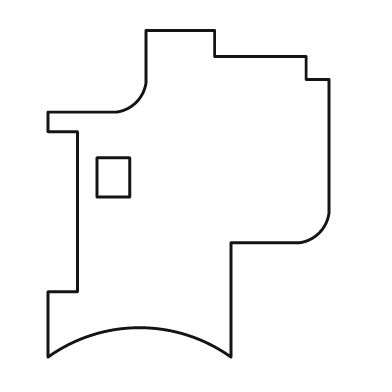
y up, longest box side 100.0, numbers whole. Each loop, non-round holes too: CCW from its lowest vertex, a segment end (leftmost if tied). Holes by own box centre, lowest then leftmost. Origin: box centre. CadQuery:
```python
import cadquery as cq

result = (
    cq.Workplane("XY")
    .moveTo(-43.0, -50.0)
    .threePointArc((-15.0, -41.0), (13.0, -50.0))
    .lineTo(13.0, -15.0)
    .lineTo(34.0, -15.0)
    .threePointArc((40.0, -12.0), (43.0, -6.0))
    .lineTo(43.0, 35.0)
    .lineTo(36.0, 35.0)
    .lineTo(36.0, 42.0)
    .lineTo(8.0, 42.0)
    .lineTo(8.0, 50.0)
    .lineTo(-13.0, 50.0)
    .lineTo(-13.0, 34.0)
    .threePointArc((-16.0, 28.0), (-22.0, 25.0))
    .lineTo(-43.0, 25.0)
    .lineTo(-43.0, 19.0)
    .lineTo(-34.0, 19.0)
    .lineTo(-34.0, -30.0)
    .lineTo(-43.0, -30.0)
    .close()
    .moveTo(-28.0, -1.0)
    .lineTo(-18.0, -1.0)
    .lineTo(-18.0, 11.0)
    .lineTo(-28.0, 11.0)
    .close()
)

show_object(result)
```